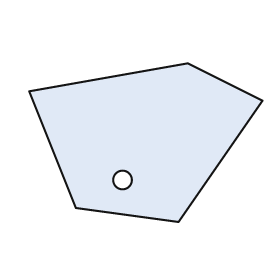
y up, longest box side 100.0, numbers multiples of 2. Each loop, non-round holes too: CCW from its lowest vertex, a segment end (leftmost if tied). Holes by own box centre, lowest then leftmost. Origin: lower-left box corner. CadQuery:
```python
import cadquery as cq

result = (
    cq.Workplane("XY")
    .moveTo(64.0, 0.0)
    .lineTo(100.0, 52.0)
    .lineTo(68.0, 68.0)
    .lineTo(0.0, 56.0)
    .lineTo(20.0, 6.0)
    .close()
    .moveTo(40.0, 18.0)
    .circle(4.0)
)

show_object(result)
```